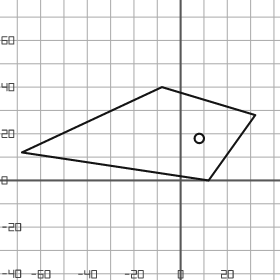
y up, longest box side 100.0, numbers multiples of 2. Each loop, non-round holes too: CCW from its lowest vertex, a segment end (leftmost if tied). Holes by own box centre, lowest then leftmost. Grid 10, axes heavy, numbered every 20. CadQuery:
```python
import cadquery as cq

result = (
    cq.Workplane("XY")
    .moveTo(12.0, 0.0)
    .lineTo(32.0, 28.0)
    .lineTo(-8.0, 40.0)
    .lineTo(-68.0, 12.0)
    .close()
    .moveTo(8.0, 18.0)
    .circle(2.0)
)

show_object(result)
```